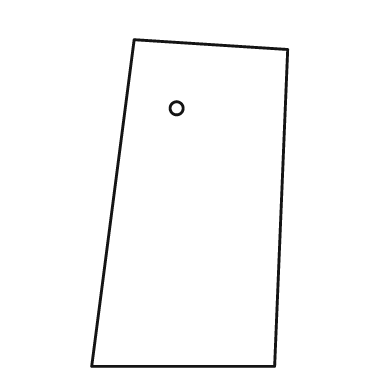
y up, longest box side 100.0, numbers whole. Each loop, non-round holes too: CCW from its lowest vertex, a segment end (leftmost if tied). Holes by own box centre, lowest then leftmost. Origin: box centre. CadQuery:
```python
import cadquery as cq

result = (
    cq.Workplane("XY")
    .moveTo(-30.0, -50.0)
    .lineTo(26.0, -50.0)
    .lineTo(30.0, 47.0)
    .lineTo(-17.0, 50.0)
    .close()
    .moveTo(-4.0, 29.0)
    .circle(2.0)
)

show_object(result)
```